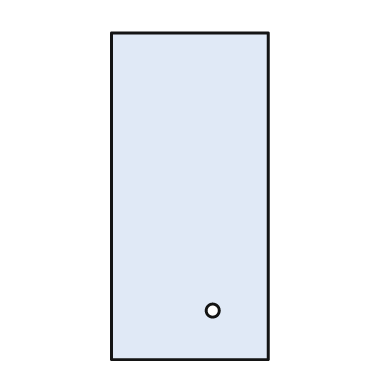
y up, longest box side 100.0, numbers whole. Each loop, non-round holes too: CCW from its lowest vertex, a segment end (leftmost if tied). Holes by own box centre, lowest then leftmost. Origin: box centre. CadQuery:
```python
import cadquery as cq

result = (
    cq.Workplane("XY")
    .moveTo(-24.0, -50.0)
    .lineTo(24.0, -50.0)
    .lineTo(24.0, 50.0)
    .lineTo(-24.0, 50.0)
    .close()
    .moveTo(7.0, -35.0)
    .circle(2.0)
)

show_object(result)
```